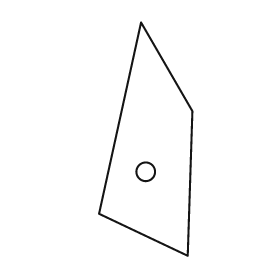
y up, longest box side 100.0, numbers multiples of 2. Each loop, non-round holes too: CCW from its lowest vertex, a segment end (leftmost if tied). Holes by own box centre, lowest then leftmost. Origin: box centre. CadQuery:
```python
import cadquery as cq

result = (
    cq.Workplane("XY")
    .moveTo(18.0, -50.0)
    .lineTo(20.0, 12.0)
    .lineTo(-2.0, 50.0)
    .lineTo(-20.0, -32.0)
    .close()
    .moveTo(0.0, -14.0)
    .circle(4.0)
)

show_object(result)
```